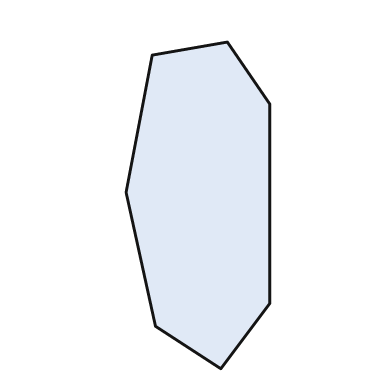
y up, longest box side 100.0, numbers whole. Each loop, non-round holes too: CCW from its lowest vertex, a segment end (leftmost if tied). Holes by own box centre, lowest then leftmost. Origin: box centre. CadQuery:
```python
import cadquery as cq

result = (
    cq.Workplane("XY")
    .moveTo(7.0, -50.0)
    .lineTo(22.0, -30.0)
    .lineTo(22.0, 31.0)
    .lineTo(9.0, 50.0)
    .lineTo(-14.0, 46.0)
    .lineTo(-22.0, 4.0)
    .lineTo(-13.0, -37.0)
    .close()
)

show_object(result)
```